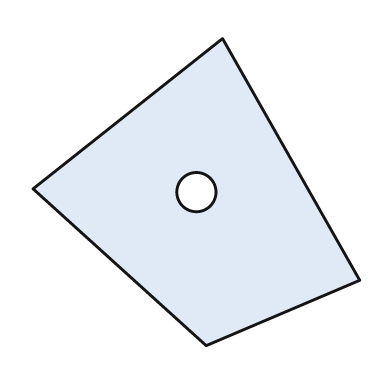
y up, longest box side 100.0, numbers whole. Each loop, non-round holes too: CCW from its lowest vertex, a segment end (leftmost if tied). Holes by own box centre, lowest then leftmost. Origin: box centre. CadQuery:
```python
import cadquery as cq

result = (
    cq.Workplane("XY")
    .moveTo(3.0, -47.0)
    .lineTo(50.0, -27.0)
    .lineTo(8.0, 47.0)
    .lineTo(-50.0, 1.0)
    .close()
    .moveTo(0.0, 0.0)
    .circle(6.0)
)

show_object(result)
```